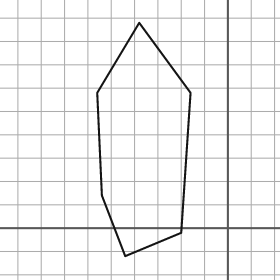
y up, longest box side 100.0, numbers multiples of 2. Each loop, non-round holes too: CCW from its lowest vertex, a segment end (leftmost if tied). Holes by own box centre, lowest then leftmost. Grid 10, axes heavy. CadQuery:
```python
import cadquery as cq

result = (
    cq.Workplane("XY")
    .moveTo(-44.0, -12.0)
    .lineTo(-20.0, -2.0)
    .lineTo(-16.0, 58.0)
    .lineTo(-38.0, 88.0)
    .lineTo(-56.0, 58.0)
    .lineTo(-54.0, 14.0)
    .close()
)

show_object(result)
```